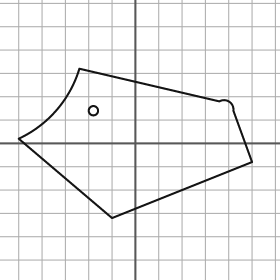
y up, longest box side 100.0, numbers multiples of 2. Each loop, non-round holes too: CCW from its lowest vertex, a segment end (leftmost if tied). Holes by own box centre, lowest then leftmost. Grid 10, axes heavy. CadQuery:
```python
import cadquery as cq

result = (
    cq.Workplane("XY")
    .moveTo(-10.0, -32.0)
    .lineTo(50.0, -8.0)
    .lineTo(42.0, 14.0)
    .threePointArc((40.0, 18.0), (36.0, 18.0))
    .lineTo(-24.0, 32.0)
    .threePointArc((-34.0, 14.0), (-50.0, 2.0))
    .close()
    .moveTo(-18.0, 14.0)
    .circle(2.0)
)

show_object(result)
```